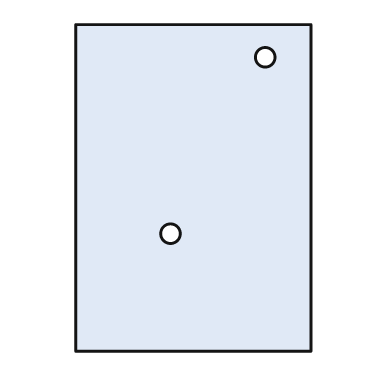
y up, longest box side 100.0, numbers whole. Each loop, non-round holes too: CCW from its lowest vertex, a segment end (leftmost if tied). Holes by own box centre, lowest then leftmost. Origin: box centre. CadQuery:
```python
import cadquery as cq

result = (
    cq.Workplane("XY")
    .moveTo(-36.0, -50.0)
    .lineTo(36.0, -50.0)
    .lineTo(36.0, 50.0)
    .lineTo(-36.0, 50.0)
    .close()
    .moveTo(-7.0, -14.0)
    .circle(3.0)
    .moveTo(22.0, 40.0)
    .circle(3.0)
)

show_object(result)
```